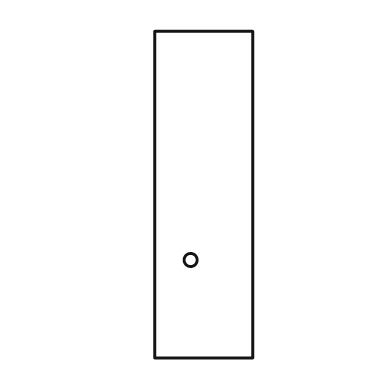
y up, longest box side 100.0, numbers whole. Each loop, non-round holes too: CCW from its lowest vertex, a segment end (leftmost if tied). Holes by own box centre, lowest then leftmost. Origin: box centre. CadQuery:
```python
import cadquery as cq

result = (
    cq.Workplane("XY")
    .moveTo(-15.0, -50.0)
    .lineTo(15.0, -50.0)
    .lineTo(15.0, 50.0)
    .lineTo(-15.0, 50.0)
    .close()
    .moveTo(-4.0, -20.0)
    .circle(2.0)
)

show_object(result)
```